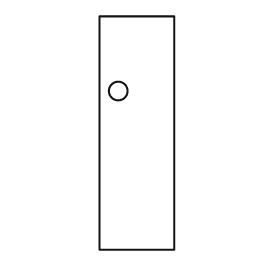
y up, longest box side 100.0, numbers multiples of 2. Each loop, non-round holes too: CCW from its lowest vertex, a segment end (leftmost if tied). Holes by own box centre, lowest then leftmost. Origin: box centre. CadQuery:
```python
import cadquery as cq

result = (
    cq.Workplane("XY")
    .moveTo(-16.0, -50.0)
    .lineTo(16.0, -50.0)
    .lineTo(16.0, 50.0)
    .lineTo(-16.0, 50.0)
    .close()
    .moveTo(-8.0, 18.0)
    .circle(4.0)
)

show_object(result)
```